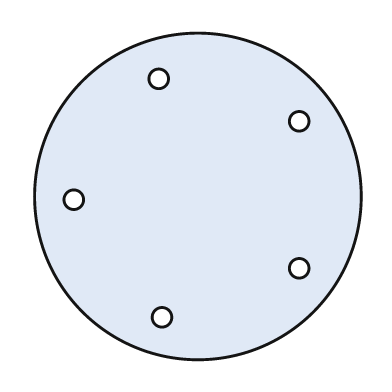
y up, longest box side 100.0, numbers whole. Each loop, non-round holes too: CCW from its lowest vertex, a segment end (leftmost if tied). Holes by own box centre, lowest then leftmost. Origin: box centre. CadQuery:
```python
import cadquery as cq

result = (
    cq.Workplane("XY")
    .moveTo(0.0, 0.0)
    .circle(50.0)
    .moveTo(-11.0, -37.0)
    .circle(3.0)
    .moveTo(31.0, -22.0)
    .circle(3.0)
    .moveTo(-38.0, -1.0)
    .circle(3.0)
    .moveTo(31.0, 23.0)
    .circle(3.0)
    .moveTo(-12.0, 36.0)
    .circle(3.0)
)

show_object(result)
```